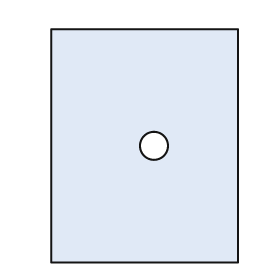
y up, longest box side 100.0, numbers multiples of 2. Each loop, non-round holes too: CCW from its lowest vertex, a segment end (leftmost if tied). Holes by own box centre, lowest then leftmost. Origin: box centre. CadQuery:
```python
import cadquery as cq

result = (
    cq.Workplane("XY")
    .moveTo(-40.0, -50.0)
    .lineTo(40.0, -50.0)
    .lineTo(40.0, 50.0)
    .lineTo(-40.0, 50.0)
    .close()
    .moveTo(4.0, 0.0)
    .circle(6.0)
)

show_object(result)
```